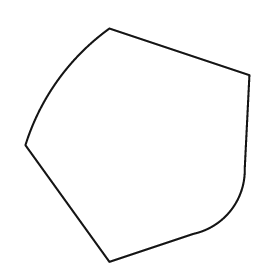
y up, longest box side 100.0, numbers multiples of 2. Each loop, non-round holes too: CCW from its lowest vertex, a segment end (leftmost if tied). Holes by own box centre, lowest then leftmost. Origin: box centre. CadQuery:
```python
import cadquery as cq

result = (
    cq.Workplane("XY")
    .moveTo(-12.0, -50.0)
    .lineTo(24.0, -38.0)
    .threePointArc((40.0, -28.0), (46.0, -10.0))
    .lineTo(48.0, 30.0)
    .lineTo(-12.0, 50.0)
    .threePointArc((-34.0, 28.0), (-48.0, 0.0))
    .close()
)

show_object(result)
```